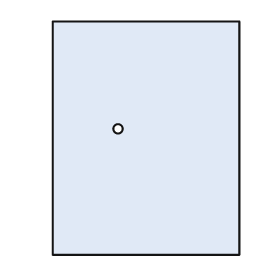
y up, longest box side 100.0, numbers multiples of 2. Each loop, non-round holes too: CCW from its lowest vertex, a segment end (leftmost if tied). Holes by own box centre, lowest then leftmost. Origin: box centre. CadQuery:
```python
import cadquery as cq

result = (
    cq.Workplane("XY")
    .moveTo(-40.0, -50.0)
    .lineTo(40.0, -50.0)
    .lineTo(40.0, 50.0)
    .lineTo(-40.0, 50.0)
    .close()
    .moveTo(-12.0, 4.0)
    .circle(2.0)
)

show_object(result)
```